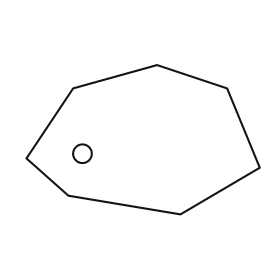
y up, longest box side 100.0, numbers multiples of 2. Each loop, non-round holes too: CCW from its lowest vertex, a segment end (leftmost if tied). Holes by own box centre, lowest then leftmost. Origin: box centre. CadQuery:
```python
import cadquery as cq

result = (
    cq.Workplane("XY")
    .moveTo(16.0, -32.0)
    .lineTo(50.0, -12.0)
    .lineTo(36.0, 22.0)
    .lineTo(6.0, 32.0)
    .lineTo(-30.0, 22.0)
    .lineTo(-50.0, -8.0)
    .lineTo(-32.0, -24.0)
    .close()
    .moveTo(-26.0, -6.0)
    .circle(4.0)
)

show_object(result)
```